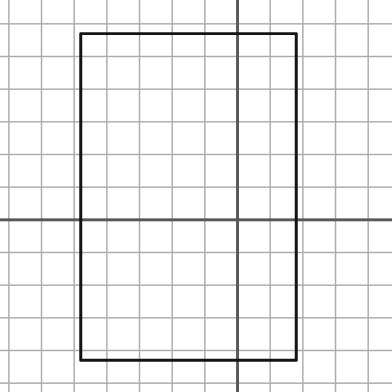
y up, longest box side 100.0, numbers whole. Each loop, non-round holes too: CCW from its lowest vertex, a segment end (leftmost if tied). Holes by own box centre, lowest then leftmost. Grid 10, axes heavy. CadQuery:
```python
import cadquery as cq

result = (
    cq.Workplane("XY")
    .moveTo(-48.0, -43.0)
    .lineTo(18.0, -43.0)
    .lineTo(18.0, 57.0)
    .lineTo(-48.0, 57.0)
    .close()
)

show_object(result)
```